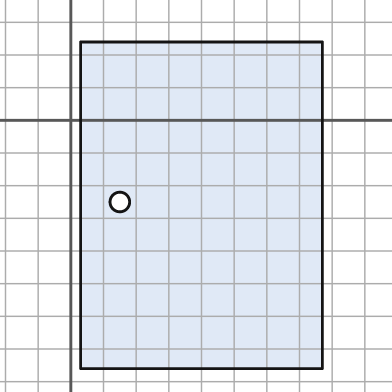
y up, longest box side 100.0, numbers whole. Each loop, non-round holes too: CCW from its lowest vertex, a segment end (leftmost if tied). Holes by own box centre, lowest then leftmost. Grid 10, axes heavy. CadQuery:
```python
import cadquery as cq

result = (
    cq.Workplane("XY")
    .moveTo(3.0, -76.0)
    .lineTo(77.0, -76.0)
    .lineTo(77.0, 24.0)
    .lineTo(3.0, 24.0)
    .close()
    .moveTo(15.0, -25.0)
    .circle(3.0)
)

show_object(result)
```